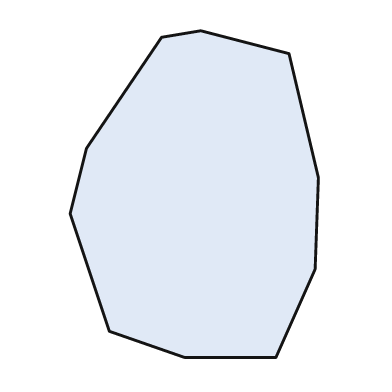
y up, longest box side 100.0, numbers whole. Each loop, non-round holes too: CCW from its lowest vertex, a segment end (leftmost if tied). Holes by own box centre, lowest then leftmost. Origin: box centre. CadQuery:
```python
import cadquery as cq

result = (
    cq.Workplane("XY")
    .moveTo(-3.0, -50.0)
    .lineTo(25.0, -50.0)
    .lineTo(37.0, -23.0)
    .lineTo(38.0, 5.0)
    .lineTo(29.0, 43.0)
    .lineTo(2.0, 50.0)
    .lineTo(-10.0, 48.0)
    .lineTo(-33.0, 14.0)
    .lineTo(-38.0, -6.0)
    .lineTo(-26.0, -42.0)
    .close()
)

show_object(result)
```